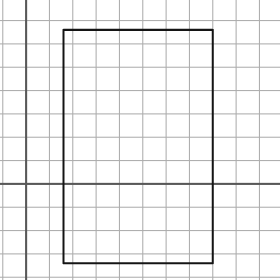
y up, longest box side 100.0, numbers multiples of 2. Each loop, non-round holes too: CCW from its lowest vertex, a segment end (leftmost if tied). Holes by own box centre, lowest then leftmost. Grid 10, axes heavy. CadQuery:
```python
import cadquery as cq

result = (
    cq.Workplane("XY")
    .moveTo(16.0, -34.0)
    .lineTo(80.0, -34.0)
    .lineTo(80.0, 66.0)
    .lineTo(16.0, 66.0)
    .close()
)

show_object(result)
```